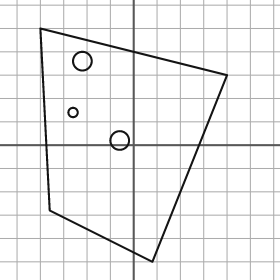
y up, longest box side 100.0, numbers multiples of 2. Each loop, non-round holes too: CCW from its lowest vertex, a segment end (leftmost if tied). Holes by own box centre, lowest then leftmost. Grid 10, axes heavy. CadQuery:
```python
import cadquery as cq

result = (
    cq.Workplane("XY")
    .moveTo(8.0, -50.0)
    .lineTo(40.0, 30.0)
    .lineTo(-40.0, 50.0)
    .lineTo(-36.0, -28.0)
    .close()
    .moveTo(-6.0, 2.0)
    .circle(4.0)
    .moveTo(-26.0, 14.0)
    .circle(2.0)
    .moveTo(-22.0, 36.0)
    .circle(4.0)
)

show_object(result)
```